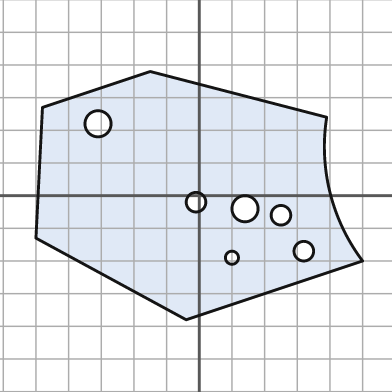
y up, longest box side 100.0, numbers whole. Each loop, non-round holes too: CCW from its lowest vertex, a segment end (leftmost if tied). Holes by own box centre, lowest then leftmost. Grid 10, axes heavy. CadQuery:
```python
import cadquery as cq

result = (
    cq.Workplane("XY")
    .moveTo(-4.0, -38.0)
    .lineTo(50.0, -20.0)
    .threePointArc((40.0, 1.0), (39.0, 24.0))
    .lineTo(-15.0, 38.0)
    .lineTo(-48.0, 27.0)
    .lineTo(-50.0, -13.0)
    .close()
    .moveTo(10.0, -19.0)
    .circle(2.0)
    .moveTo(32.0, -17.0)
    .circle(3.0)
    .moveTo(25.0, -6.0)
    .circle(3.0)
    .moveTo(14.0, -4.0)
    .circle(4.0)
    .moveTo(-1.0, -2.0)
    .circle(3.0)
    .moveTo(-31.0, 22.0)
    .circle(4.0)
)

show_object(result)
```